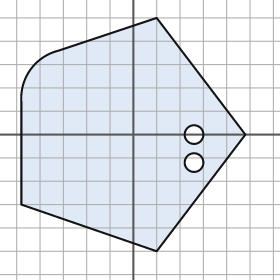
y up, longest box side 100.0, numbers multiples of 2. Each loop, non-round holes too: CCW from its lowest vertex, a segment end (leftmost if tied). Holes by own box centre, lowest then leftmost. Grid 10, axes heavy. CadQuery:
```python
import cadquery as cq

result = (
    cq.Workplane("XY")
    .moveTo(10.0, -50.0)
    .lineTo(48.0, 0.0)
    .lineTo(10.0, 50.0)
    .lineTo(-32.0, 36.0)
    .threePointArc((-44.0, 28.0), (-48.0, 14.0))
    .lineTo(-48.0, -30.0)
    .close()
    .moveTo(26.0, -12.0)
    .circle(4.0)
    .moveTo(26.0, 0.0)
    .circle(4.0)
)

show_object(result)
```